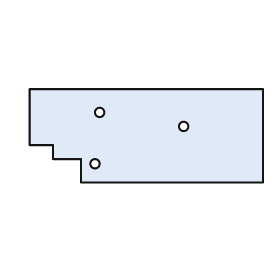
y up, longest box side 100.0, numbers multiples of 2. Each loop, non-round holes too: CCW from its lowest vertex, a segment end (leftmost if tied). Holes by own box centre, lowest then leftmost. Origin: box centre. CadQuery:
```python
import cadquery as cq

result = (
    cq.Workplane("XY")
    .moveTo(-28.0, -20.0)
    .lineTo(50.0, -20.0)
    .lineTo(50.0, 20.0)
    .lineTo(-50.0, 20.0)
    .lineTo(-50.0, -4.0)
    .lineTo(-40.0, -4.0)
    .lineTo(-40.0, -10.0)
    .lineTo(-28.0, -10.0)
    .close()
    .moveTo(-22.0, -12.0)
    .circle(2.0)
    .moveTo(16.0, 4.0)
    .circle(2.0)
    .moveTo(-20.0, 10.0)
    .circle(2.0)
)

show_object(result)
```